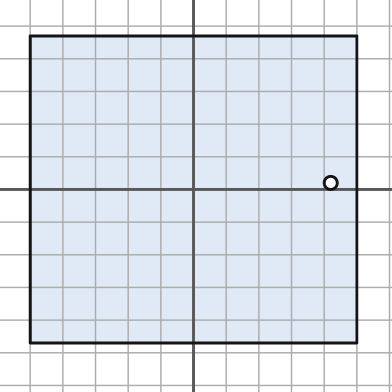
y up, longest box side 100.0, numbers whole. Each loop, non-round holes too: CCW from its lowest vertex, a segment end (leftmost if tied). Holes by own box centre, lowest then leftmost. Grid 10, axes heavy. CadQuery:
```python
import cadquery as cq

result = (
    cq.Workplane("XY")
    .moveTo(-50.0, -47.0)
    .lineTo(50.0, -47.0)
    .lineTo(50.0, 47.0)
    .lineTo(-50.0, 47.0)
    .close()
    .moveTo(42.0, 2.0)
    .circle(2.0)
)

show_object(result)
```